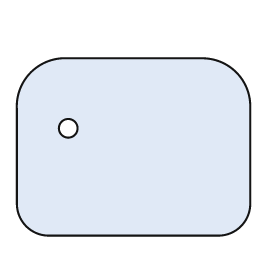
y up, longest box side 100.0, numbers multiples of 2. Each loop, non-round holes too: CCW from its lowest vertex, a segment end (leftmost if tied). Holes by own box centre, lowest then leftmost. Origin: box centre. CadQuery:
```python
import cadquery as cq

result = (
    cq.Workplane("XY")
    .moveTo(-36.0, -38.0)
    .lineTo(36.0, -38.0)
    .threePointArc((46.0, -34.0), (50.0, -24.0))
    .lineTo(50.0, 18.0)
    .threePointArc((44.0, 32.0), (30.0, 38.0))
    .lineTo(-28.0, 38.0)
    .threePointArc((-44.0, 32.0), (-50.0, 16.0))
    .lineTo(-50.0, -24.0)
    .threePointArc((-46.0, -34.0), (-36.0, -38.0))
    .close()
    .moveTo(-28.0, 8.0)
    .circle(4.0)
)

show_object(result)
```